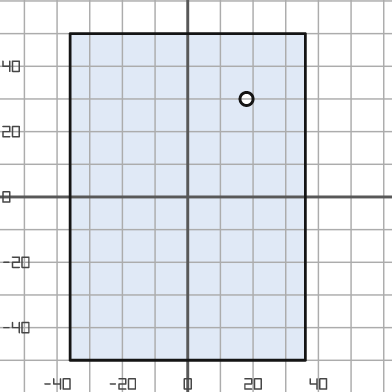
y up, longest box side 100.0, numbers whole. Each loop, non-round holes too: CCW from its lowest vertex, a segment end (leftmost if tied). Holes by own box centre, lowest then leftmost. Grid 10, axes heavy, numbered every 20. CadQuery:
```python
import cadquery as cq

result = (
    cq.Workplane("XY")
    .moveTo(-36.0, -50.0)
    .lineTo(36.0, -50.0)
    .lineTo(36.0, 50.0)
    .lineTo(-36.0, 50.0)
    .close()
    .moveTo(18.0, 30.0)
    .circle(2.0)
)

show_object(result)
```